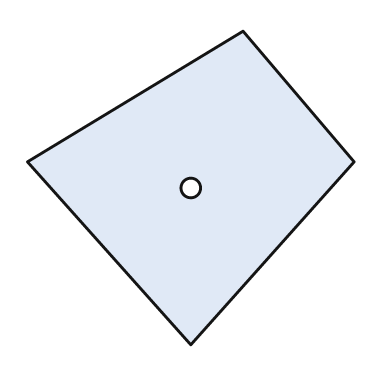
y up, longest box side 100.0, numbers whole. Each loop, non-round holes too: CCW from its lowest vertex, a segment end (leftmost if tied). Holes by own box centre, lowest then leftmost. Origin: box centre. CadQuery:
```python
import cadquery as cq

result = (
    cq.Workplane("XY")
    .moveTo(0.0, -48.0)
    .lineTo(50.0, 8.0)
    .lineTo(16.0, 48.0)
    .lineTo(-50.0, 8.0)
    .close()
    .moveTo(0.0, 0.0)
    .circle(3.0)
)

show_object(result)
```